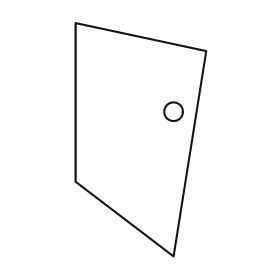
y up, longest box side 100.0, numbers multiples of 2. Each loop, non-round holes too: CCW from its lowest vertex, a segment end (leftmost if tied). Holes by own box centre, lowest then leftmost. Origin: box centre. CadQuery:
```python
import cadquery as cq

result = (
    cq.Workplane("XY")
    .moveTo(14.0, -50.0)
    .lineTo(28.0, 38.0)
    .lineTo(-28.0, 50.0)
    .lineTo(-28.0, -18.0)
    .close()
    .moveTo(14.0, 12.0)
    .circle(4.0)
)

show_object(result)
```